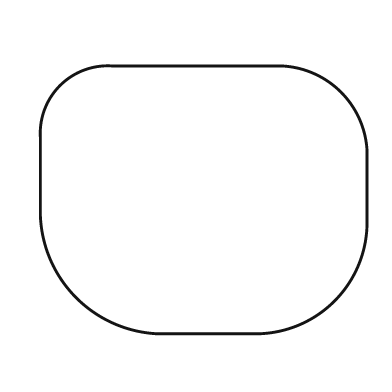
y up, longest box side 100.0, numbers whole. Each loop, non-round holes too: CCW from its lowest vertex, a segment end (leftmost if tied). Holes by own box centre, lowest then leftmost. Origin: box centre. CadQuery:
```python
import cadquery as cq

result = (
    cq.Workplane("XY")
    .moveTo(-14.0, -41.0)
    .lineTo(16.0, -41.0)
    .threePointArc((40.0, -31.0), (50.0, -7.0))
    .lineTo(50.0, 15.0)
    .threePointArc((42.0, 33.0), (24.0, 41.0))
    .lineTo(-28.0, 41.0)
    .threePointArc((-44.0, 35.0), (-50.0, 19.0))
    .lineTo(-50.0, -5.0)
    .threePointArc((-39.0, -30.0), (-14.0, -41.0))
    .close()
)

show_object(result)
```